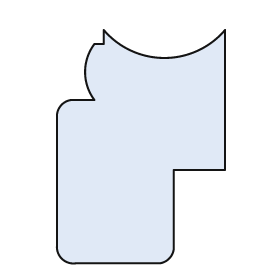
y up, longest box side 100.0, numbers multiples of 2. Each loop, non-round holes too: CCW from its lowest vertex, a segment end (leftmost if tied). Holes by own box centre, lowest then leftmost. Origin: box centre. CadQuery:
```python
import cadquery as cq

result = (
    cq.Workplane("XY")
    .moveTo(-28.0, -50.0)
    .lineTo(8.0, -50.0)
    .threePointArc((12.0, -48.0), (14.0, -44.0))
    .lineTo(14.0, -10.0)
    .lineTo(36.0, -10.0)
    .lineTo(36.0, 50.0)
    .threePointArc((10.0, 38.0), (-16.0, 50.0))
    .lineTo(-16.0, 44.0)
    .lineTo(-20.0, 44.0)
    .threePointArc((-24.0, 32.0), (-20.0, 20.0))
    .lineTo(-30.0, 20.0)
    .threePointArc((-34.0, 18.0), (-36.0, 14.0))
    .lineTo(-36.0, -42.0)
    .threePointArc((-34.0, -48.0), (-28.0, -50.0))
    .close()
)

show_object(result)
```